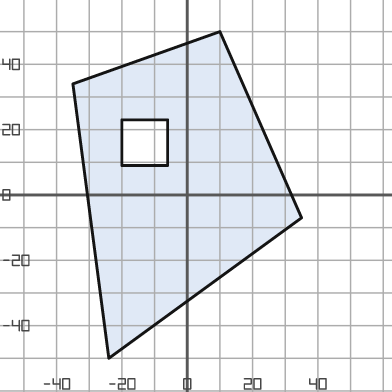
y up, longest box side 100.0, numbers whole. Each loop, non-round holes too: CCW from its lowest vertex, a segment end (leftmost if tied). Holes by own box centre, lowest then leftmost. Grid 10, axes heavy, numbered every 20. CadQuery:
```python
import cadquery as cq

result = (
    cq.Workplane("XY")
    .moveTo(-24.0, -50.0)
    .lineTo(35.0, -7.0)
    .lineTo(10.0, 50.0)
    .lineTo(-35.0, 34.0)
    .close()
    .moveTo(-20.0, 9.0)
    .lineTo(-6.0, 9.0)
    .lineTo(-6.0, 23.0)
    .lineTo(-20.0, 23.0)
    .close()
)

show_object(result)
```